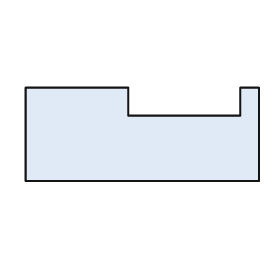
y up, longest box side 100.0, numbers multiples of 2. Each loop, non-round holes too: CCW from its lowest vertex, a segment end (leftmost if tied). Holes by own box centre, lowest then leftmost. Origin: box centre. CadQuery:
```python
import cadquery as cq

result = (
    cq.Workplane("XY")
    .moveTo(-50.0, -20.0)
    .lineTo(50.0, -20.0)
    .lineTo(50.0, 20.0)
    .lineTo(42.0, 20.0)
    .lineTo(42.0, 8.0)
    .lineTo(-6.0, 8.0)
    .lineTo(-6.0, 20.0)
    .lineTo(-50.0, 20.0)
    .close()
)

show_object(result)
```